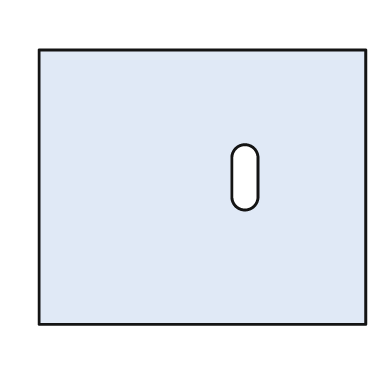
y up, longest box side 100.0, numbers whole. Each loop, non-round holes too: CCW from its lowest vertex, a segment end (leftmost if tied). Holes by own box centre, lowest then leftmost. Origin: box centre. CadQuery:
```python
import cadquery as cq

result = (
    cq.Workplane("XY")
    .moveTo(-50.0, -42.0)
    .lineTo(50.0, -42.0)
    .lineTo(50.0, 42.0)
    .lineTo(-50.0, 42.0)
    .close()
    .moveTo(9.0, -3.0)
    .threePointArc((13.0, -7.0), (17.0, -3.0))
    .lineTo(17.0, 9.0)
    .threePointArc((13.0, 13.0), (9.0, 9.0))
    .close()
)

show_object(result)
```